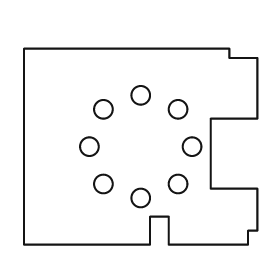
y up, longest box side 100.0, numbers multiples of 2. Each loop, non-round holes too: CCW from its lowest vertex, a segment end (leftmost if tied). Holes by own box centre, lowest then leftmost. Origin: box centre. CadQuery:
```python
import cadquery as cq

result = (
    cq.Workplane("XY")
    .moveTo(-50.0, -42.0)
    .lineTo(4.0, -42.0)
    .lineTo(4.0, -30.0)
    .lineTo(12.0, -30.0)
    .lineTo(12.0, -42.0)
    .lineTo(46.0, -42.0)
    .lineTo(46.0, -36.0)
    .lineTo(50.0, -36.0)
    .lineTo(50.0, -18.0)
    .lineTo(30.0, -18.0)
    .lineTo(30.0, 12.0)
    .lineTo(50.0, 12.0)
    .lineTo(50.0, 38.0)
    .lineTo(38.0, 38.0)
    .lineTo(38.0, 42.0)
    .lineTo(-50.0, 42.0)
    .close()
    .moveTo(0.0, -22.0)
    .circle(4.0)
    .moveTo(-16.0, -16.0)
    .circle(4.0)
    .moveTo(16.0, -16.0)
    .circle(4.0)
    .moveTo(-22.0, 0.0)
    .circle(4.0)
    .moveTo(22.0, 0.0)
    .circle(4.0)
    .moveTo(-16.0, 16.0)
    .circle(4.0)
    .moveTo(16.0, 16.0)
    .circle(4.0)
    .moveTo(0.0, 22.0)
    .circle(4.0)
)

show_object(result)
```